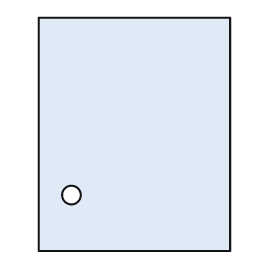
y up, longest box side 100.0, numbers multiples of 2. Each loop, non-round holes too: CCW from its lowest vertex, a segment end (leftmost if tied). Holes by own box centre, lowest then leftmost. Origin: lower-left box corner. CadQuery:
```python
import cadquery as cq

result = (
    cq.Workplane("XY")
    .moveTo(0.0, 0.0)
    .lineTo(82.0, 0.0)
    .lineTo(82.0, 100.0)
    .lineTo(0.0, 100.0)
    .close()
    .moveTo(14.0, 24.0)
    .circle(4.0)
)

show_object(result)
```